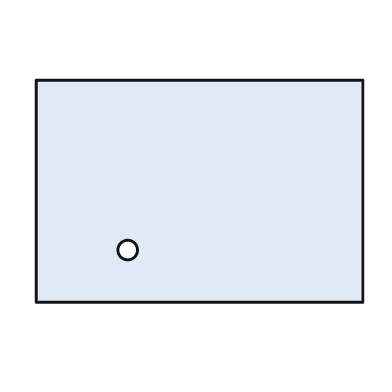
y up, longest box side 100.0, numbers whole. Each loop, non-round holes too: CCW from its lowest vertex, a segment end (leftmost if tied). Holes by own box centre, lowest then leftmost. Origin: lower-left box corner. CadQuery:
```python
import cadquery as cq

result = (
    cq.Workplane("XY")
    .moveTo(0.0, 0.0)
    .lineTo(100.0, 0.0)
    .lineTo(100.0, 68.0)
    .lineTo(0.0, 68.0)
    .close()
    .moveTo(28.0, 16.0)
    .circle(3.0)
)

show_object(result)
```